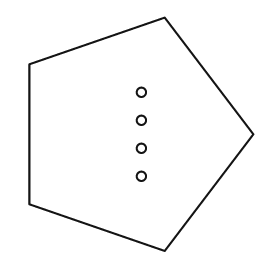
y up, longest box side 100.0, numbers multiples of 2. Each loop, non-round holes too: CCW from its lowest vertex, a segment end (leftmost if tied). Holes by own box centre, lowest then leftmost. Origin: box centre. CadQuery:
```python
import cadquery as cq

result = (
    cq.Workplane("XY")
    .moveTo(10.0, -50.0)
    .lineTo(48.0, 0.0)
    .lineTo(10.0, 50.0)
    .lineTo(-48.0, 30.0)
    .lineTo(-48.0, -30.0)
    .close()
    .moveTo(0.0, -18.0)
    .circle(2.0)
    .moveTo(0.0, -6.0)
    .circle(2.0)
    .moveTo(0.0, 6.0)
    .circle(2.0)
    .moveTo(0.0, 18.0)
    .circle(2.0)
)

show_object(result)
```